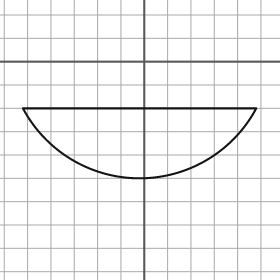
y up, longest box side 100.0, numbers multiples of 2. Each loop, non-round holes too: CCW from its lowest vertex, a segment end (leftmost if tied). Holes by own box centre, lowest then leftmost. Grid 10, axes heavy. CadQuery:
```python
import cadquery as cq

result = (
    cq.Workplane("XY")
    .moveTo(-52.0, -20.0)
    .threePointArc((-2.0, -50.0), (48.0, -20.0))
    .close()
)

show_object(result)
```